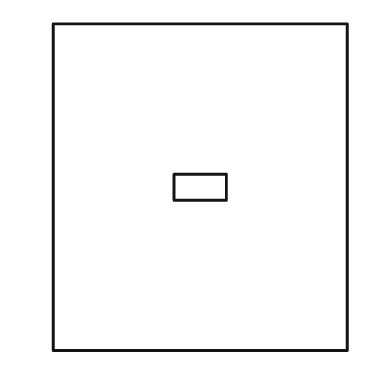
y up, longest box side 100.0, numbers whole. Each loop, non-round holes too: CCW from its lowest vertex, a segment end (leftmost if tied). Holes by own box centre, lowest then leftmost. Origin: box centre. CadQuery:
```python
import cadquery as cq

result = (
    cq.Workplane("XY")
    .moveTo(-45.0, -50.0)
    .lineTo(45.0, -50.0)
    .lineTo(45.0, 50.0)
    .lineTo(-45.0, 50.0)
    .close()
    .moveTo(-8.0, -4.0)
    .lineTo(8.0, -4.0)
    .lineTo(8.0, 4.0)
    .lineTo(-8.0, 4.0)
    .close()
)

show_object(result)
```